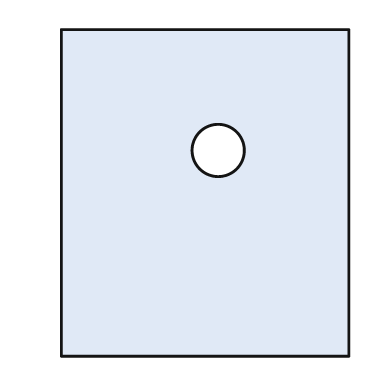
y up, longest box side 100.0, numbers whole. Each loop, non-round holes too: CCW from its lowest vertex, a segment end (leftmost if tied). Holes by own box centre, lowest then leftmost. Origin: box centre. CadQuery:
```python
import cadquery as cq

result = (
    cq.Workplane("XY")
    .moveTo(-44.0, -50.0)
    .lineTo(44.0, -50.0)
    .lineTo(44.0, 50.0)
    .lineTo(-44.0, 50.0)
    .close()
    .moveTo(4.0, 13.0)
    .circle(8.0)
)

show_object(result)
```